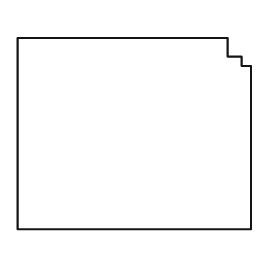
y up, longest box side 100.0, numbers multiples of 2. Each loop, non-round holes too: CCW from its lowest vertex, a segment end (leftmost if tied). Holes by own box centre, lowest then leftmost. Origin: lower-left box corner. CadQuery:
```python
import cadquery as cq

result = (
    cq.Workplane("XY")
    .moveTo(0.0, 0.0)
    .lineTo(100.0, 0.0)
    .lineTo(100.0, 70.0)
    .lineTo(96.0, 70.0)
    .lineTo(96.0, 74.0)
    .lineTo(90.0, 74.0)
    .lineTo(90.0, 82.0)
    .lineTo(0.0, 82.0)
    .close()
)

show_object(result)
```